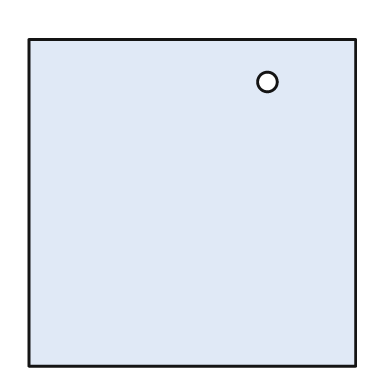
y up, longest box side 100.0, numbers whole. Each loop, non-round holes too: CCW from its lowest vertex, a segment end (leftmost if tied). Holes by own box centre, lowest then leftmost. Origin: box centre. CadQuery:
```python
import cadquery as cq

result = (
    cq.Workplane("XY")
    .moveTo(-50.0, -50.0)
    .lineTo(50.0, -50.0)
    .lineTo(50.0, 50.0)
    .lineTo(-50.0, 50.0)
    .close()
    .moveTo(23.0, 37.0)
    .circle(3.0)
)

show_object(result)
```